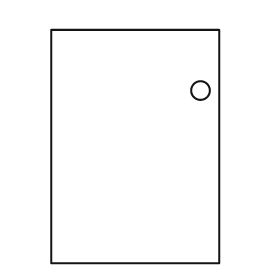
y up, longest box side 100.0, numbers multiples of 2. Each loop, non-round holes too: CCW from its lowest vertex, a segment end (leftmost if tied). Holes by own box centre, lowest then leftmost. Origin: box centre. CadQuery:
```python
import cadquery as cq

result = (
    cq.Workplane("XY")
    .moveTo(-36.0, -50.0)
    .lineTo(36.0, -50.0)
    .lineTo(36.0, 50.0)
    .lineTo(-36.0, 50.0)
    .close()
    .moveTo(28.0, 24.0)
    .circle(4.0)
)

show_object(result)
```